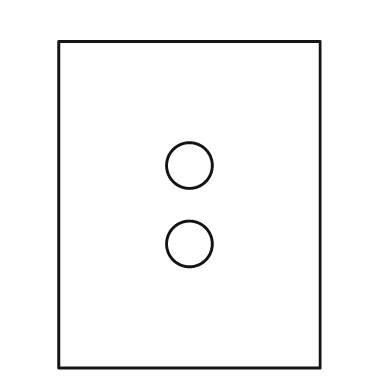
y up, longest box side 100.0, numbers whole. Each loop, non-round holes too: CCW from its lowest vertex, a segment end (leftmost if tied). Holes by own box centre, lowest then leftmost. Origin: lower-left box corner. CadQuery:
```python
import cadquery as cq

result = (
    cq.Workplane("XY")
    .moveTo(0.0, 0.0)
    .lineTo(80.0, 0.0)
    .lineTo(80.0, 100.0)
    .lineTo(0.0, 100.0)
    .close()
    .moveTo(40.0, 38.0)
    .circle(7.0)
    .moveTo(40.0, 62.0)
    .circle(7.0)
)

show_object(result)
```